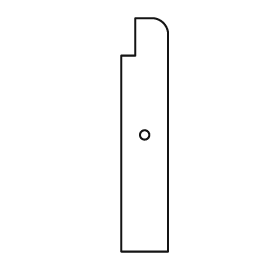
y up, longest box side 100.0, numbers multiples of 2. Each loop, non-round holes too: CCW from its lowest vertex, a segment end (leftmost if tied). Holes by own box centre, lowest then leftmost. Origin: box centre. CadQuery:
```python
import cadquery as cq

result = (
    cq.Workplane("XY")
    .moveTo(-10.0, -50.0)
    .lineTo(10.0, -50.0)
    .lineTo(10.0, 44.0)
    .threePointArc((8.0, 48.0), (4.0, 50.0))
    .lineTo(-4.0, 50.0)
    .lineTo(-4.0, 34.0)
    .lineTo(-10.0, 34.0)
    .close()
    .moveTo(0.0, 0.0)
    .circle(2.0)
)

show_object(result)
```